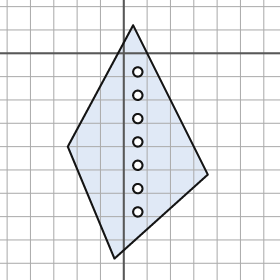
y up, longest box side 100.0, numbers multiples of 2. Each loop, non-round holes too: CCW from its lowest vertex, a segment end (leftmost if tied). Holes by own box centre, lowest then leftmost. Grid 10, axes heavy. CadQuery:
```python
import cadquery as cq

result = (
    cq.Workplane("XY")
    .moveTo(-4.0, -88.0)
    .lineTo(36.0, -52.0)
    .lineTo(4.0, 12.0)
    .lineTo(-24.0, -40.0)
    .close()
    .moveTo(6.0, -68.0)
    .circle(2.0)
    .moveTo(6.0, -58.0)
    .circle(2.0)
    .moveTo(6.0, -48.0)
    .circle(2.0)
    .moveTo(6.0, -38.0)
    .circle(2.0)
    .moveTo(6.0, -28.0)
    .circle(2.0)
    .moveTo(6.0, -18.0)
    .circle(2.0)
    .moveTo(6.0, -8.0)
    .circle(2.0)
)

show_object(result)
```